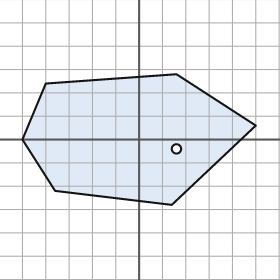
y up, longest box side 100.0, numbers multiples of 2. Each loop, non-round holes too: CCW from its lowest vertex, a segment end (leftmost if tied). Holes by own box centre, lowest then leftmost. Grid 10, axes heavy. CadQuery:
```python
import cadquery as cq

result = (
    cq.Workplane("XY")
    .moveTo(14.0, -28.0)
    .lineTo(50.0, 6.0)
    .lineTo(16.0, 28.0)
    .lineTo(-40.0, 24.0)
    .lineTo(-50.0, 0.0)
    .lineTo(-36.0, -22.0)
    .close()
    .moveTo(16.0, -4.0)
    .circle(2.0)
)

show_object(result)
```